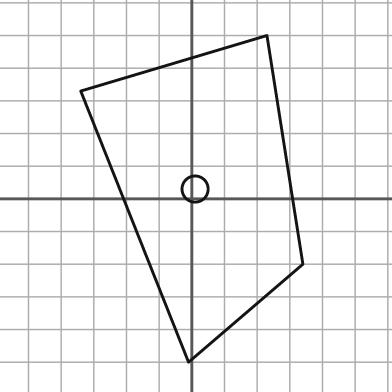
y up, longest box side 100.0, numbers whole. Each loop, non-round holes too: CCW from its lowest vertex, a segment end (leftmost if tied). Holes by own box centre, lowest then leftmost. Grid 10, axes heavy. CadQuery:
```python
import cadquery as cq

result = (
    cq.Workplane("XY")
    .moveTo(-1.0, -50.0)
    .lineTo(34.0, -20.0)
    .lineTo(23.0, 50.0)
    .lineTo(-34.0, 33.0)
    .close()
    .moveTo(1.0, 3.0)
    .circle(4.0)
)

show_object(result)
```